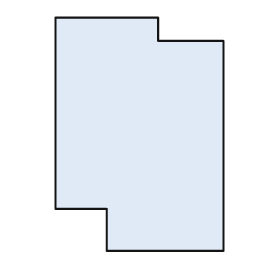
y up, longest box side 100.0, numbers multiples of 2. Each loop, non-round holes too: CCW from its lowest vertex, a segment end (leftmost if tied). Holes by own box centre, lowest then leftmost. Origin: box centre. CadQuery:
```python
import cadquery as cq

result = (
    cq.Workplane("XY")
    .moveTo(-14.0, -50.0)
    .lineTo(36.0, -50.0)
    .lineTo(36.0, 40.0)
    .lineTo(8.0, 40.0)
    .lineTo(8.0, 50.0)
    .lineTo(-36.0, 50.0)
    .lineTo(-36.0, -32.0)
    .lineTo(-14.0, -32.0)
    .close()
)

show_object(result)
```